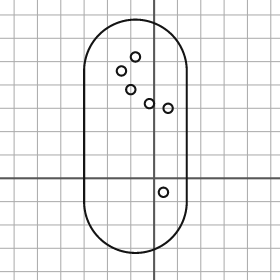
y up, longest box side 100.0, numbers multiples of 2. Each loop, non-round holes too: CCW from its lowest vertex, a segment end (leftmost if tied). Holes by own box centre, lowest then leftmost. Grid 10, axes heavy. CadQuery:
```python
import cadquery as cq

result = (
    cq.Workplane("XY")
    .moveTo(-30.0, -10.0)
    .threePointArc((-8.0, -32.0), (14.0, -10.0))
    .lineTo(14.0, 46.0)
    .threePointArc((-8.0, 68.0), (-30.0, 46.0))
    .close()
    .moveTo(4.0, -6.0)
    .circle(2.0)
    .moveTo(6.0, 30.0)
    .circle(2.0)
    .moveTo(-2.0, 32.0)
    .circle(2.0)
    .moveTo(-10.0, 38.0)
    .circle(2.0)
    .moveTo(-14.0, 46.0)
    .circle(2.0)
    .moveTo(-8.0, 52.0)
    .circle(2.0)
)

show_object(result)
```